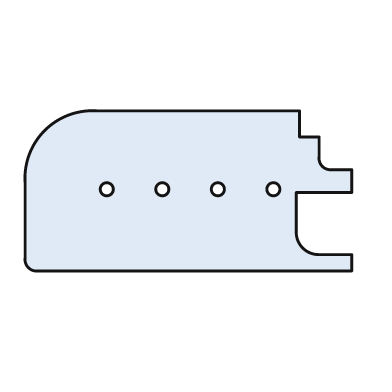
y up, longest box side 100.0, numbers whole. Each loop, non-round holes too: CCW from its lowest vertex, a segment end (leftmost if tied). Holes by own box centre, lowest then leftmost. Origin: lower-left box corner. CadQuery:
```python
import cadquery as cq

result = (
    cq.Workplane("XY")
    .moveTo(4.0, 0.0)
    .lineTo(100.0, 0.0)
    .lineTo(100.0, 5.0)
    .lineTo(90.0, 5.0)
    .threePointArc((85.0, 7.0), (83.0, 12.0))
    .lineTo(83.0, 24.0)
    .lineTo(100.0, 24.0)
    .lineTo(100.0, 31.0)
    .lineTo(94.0, 31.0)
    .threePointArc((91.0, 32.0), (90.0, 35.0))
    .lineTo(90.0, 41.0)
    .lineTo(84.0, 41.0)
    .lineTo(84.0, 49.0)
    .lineTo(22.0, 49.0)
    .threePointArc((6.0, 43.0), (0.0, 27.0))
    .lineTo(0.0, 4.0)
    .threePointArc((1.0, 1.0), (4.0, 0.0))
    .close()
    .moveTo(25.0, 25.0)
    .circle(2.0)
    .moveTo(42.0, 25.0)
    .circle(2.0)
    .moveTo(59.0, 25.0)
    .circle(2.0)
    .moveTo(76.0, 25.0)
    .circle(2.0)
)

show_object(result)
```